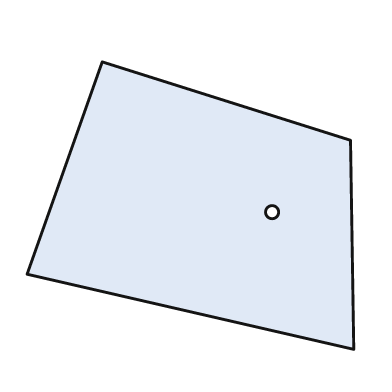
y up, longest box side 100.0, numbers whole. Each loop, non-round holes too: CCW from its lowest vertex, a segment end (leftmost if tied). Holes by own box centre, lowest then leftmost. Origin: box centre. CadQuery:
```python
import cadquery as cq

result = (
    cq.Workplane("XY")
    .moveTo(50.0, -44.0)
    .lineTo(49.0, 20.0)
    .lineTo(-27.0, 44.0)
    .lineTo(-50.0, -21.0)
    .close()
    .moveTo(25.0, -2.0)
    .circle(2.0)
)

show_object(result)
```